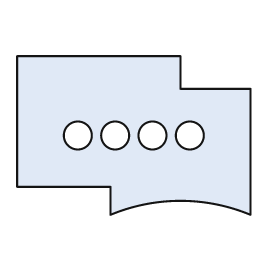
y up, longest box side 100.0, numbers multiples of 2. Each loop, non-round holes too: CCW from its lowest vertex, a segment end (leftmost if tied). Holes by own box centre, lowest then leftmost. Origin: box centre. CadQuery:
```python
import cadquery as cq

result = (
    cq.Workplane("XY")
    .moveTo(-10.0, -34.0)
    .threePointArc((20.0, -28.0), (50.0, -34.0))
    .lineTo(50.0, 20.0)
    .lineTo(20.0, 20.0)
    .lineTo(20.0, 34.0)
    .lineTo(-50.0, 34.0)
    .lineTo(-50.0, -22.0)
    .lineTo(-10.0, -22.0)
    .close()
    .moveTo(-24.0, 0.0)
    .circle(6.0)
    .moveTo(-8.0, 0.0)
    .circle(6.0)
    .moveTo(8.0, 0.0)
    .circle(6.0)
    .moveTo(24.0, 0.0)
    .circle(6.0)
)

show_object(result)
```